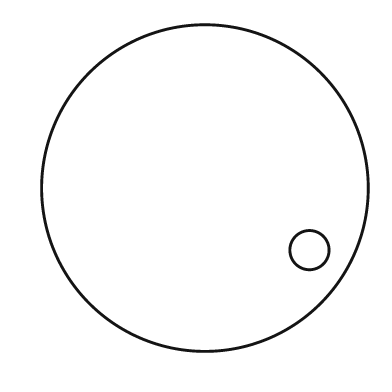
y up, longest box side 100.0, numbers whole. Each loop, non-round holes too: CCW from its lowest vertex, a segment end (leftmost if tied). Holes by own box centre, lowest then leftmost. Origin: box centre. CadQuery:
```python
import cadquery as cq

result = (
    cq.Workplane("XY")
    .moveTo(0.0, 0.0)
    .circle(50.0)
    .moveTo(32.0, -19.0)
    .circle(6.0)
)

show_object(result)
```